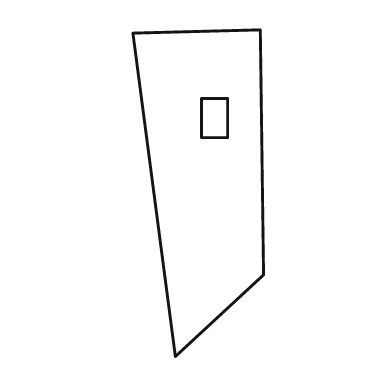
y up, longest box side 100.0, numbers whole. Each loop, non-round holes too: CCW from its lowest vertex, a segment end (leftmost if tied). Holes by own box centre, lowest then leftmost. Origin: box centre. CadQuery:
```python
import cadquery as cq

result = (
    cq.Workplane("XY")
    .moveTo(-7.0, -50.0)
    .lineTo(20.0, -25.0)
    .lineTo(19.0, 50.0)
    .lineTo(-20.0, 49.0)
    .close()
    .moveTo(1.0, 17.0)
    .lineTo(9.0, 17.0)
    .lineTo(9.0, 29.0)
    .lineTo(1.0, 29.0)
    .close()
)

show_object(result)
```